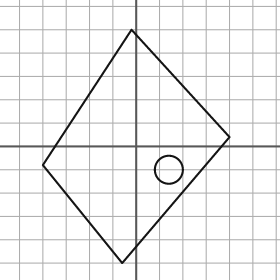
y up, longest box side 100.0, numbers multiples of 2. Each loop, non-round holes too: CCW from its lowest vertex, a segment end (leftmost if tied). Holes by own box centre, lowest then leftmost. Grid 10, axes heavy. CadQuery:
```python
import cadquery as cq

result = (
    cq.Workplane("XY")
    .moveTo(-6.0, -50.0)
    .lineTo(40.0, 4.0)
    .lineTo(-2.0, 50.0)
    .lineTo(-40.0, -8.0)
    .close()
    .moveTo(14.0, -10.0)
    .circle(6.0)
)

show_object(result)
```